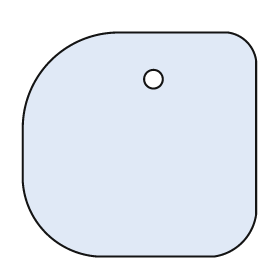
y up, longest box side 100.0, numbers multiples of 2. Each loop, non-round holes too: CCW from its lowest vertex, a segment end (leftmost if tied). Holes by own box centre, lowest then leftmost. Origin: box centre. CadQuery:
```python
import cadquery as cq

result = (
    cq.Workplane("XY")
    .moveTo(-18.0, -48.0)
    .lineTo(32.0, -48.0)
    .threePointArc((44.0, -42.0), (50.0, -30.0))
    .lineTo(50.0, 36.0)
    .threePointArc((46.0, 44.0), (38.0, 48.0))
    .lineTo(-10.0, 48.0)
    .threePointArc((-38.0, 36.0), (-50.0, 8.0))
    .lineTo(-50.0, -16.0)
    .threePointArc((-40.0, -38.0), (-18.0, -48.0))
    .close()
    .moveTo(6.0, 28.0)
    .circle(4.0)
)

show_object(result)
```